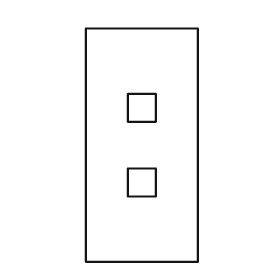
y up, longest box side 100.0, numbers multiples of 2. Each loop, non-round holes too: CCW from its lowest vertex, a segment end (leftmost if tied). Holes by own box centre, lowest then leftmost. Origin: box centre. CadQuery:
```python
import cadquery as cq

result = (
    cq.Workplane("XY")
    .moveTo(-24.0, -50.0)
    .lineTo(24.0, -50.0)
    .lineTo(24.0, 50.0)
    .lineTo(-24.0, 50.0)
    .close()
    .moveTo(-6.0, -22.0)
    .lineTo(6.0, -22.0)
    .lineTo(6.0, -10.0)
    .lineTo(-6.0, -10.0)
    .close()
    .moveTo(-6.0, 10.0)
    .lineTo(6.0, 10.0)
    .lineTo(6.0, 22.0)
    .lineTo(-6.0, 22.0)
    .close()
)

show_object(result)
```